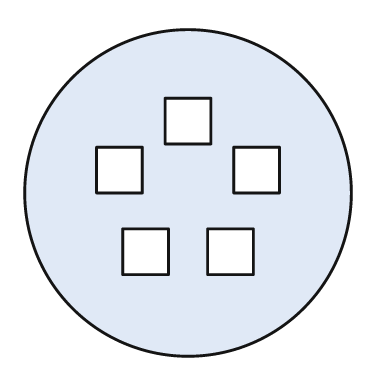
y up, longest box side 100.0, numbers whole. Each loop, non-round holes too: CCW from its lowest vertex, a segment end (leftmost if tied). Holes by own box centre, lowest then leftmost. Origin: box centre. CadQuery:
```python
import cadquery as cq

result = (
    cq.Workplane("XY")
    .moveTo(0.0, 0.0)
    .circle(50.0)
    .moveTo(-20.0, -25.0)
    .lineTo(-6.0, -25.0)
    .lineTo(-6.0, -11.0)
    .lineTo(-20.0, -11.0)
    .close()
    .moveTo(6.0, -25.0)
    .lineTo(20.0, -25.0)
    .lineTo(20.0, -11.0)
    .lineTo(6.0, -11.0)
    .close()
    .moveTo(-28.0, 0.0)
    .lineTo(-14.0, 0.0)
    .lineTo(-14.0, 14.0)
    .lineTo(-28.0, 14.0)
    .close()
    .moveTo(14.0, 0.0)
    .lineTo(28.0, 0.0)
    .lineTo(28.0, 14.0)
    .lineTo(14.0, 14.0)
    .close()
    .moveTo(-7.0, 15.0)
    .lineTo(7.0, 15.0)
    .lineTo(7.0, 29.0)
    .lineTo(-7.0, 29.0)
    .close()
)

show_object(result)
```